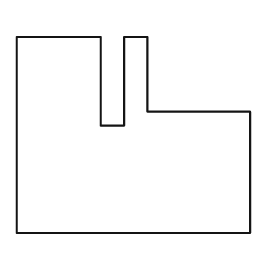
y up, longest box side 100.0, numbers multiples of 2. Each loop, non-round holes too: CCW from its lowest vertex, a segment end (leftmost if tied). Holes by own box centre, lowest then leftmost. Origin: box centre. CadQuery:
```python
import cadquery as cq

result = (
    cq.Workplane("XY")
    .moveTo(-50.0, -42.0)
    .lineTo(50.0, -42.0)
    .lineTo(50.0, 10.0)
    .lineTo(6.0, 10.0)
    .lineTo(6.0, 42.0)
    .lineTo(-4.0, 42.0)
    .lineTo(-4.0, 4.0)
    .lineTo(-14.0, 4.0)
    .lineTo(-14.0, 42.0)
    .lineTo(-50.0, 42.0)
    .close()
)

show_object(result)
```